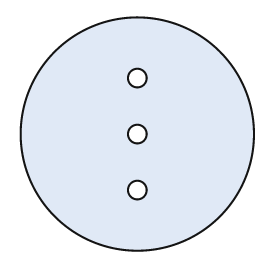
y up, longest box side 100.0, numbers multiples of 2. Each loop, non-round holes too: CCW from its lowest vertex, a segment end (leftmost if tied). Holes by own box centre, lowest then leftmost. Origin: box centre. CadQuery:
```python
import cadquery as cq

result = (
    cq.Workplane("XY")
    .moveTo(0.0, 0.0)
    .circle(50.0)
    .moveTo(0.0, -24.0)
    .circle(4.0)
    .moveTo(0.0, 0.0)
    .circle(4.0)
    .moveTo(0.0, 24.0)
    .circle(4.0)
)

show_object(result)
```